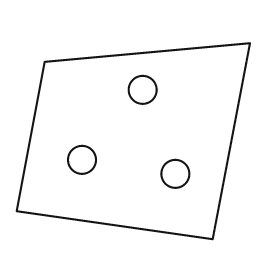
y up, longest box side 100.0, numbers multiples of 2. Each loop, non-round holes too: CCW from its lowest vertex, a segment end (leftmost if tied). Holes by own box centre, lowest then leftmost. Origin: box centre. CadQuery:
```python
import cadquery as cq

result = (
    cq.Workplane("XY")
    .moveTo(34.0, -42.0)
    .lineTo(50.0, 42.0)
    .lineTo(-38.0, 34.0)
    .lineTo(-50.0, -30.0)
    .close()
    .moveTo(18.0, -14.0)
    .circle(6.0)
    .moveTo(-22.0, -8.0)
    .circle(6.0)
    .moveTo(4.0, 22.0)
    .circle(6.0)
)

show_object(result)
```